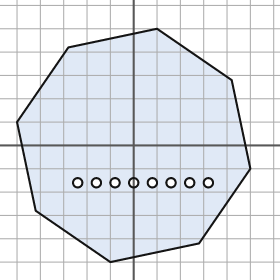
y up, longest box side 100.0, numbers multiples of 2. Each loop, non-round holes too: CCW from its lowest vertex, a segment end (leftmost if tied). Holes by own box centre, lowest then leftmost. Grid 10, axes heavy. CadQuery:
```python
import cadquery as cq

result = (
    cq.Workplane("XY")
    .moveTo(-10.0, -50.0)
    .lineTo(28.0, -42.0)
    .lineTo(50.0, -10.0)
    .lineTo(42.0, 28.0)
    .lineTo(10.0, 50.0)
    .lineTo(-28.0, 42.0)
    .lineTo(-50.0, 10.0)
    .lineTo(-42.0, -28.0)
    .close()
    .moveTo(-24.0, -16.0)
    .circle(2.0)
    .moveTo(-16.0, -16.0)
    .circle(2.0)
    .moveTo(-8.0, -16.0)
    .circle(2.0)
    .moveTo(0.0, -16.0)
    .circle(2.0)
    .moveTo(8.0, -16.0)
    .circle(2.0)
    .moveTo(16.0, -16.0)
    .circle(2.0)
    .moveTo(24.0, -16.0)
    .circle(2.0)
    .moveTo(32.0, -16.0)
    .circle(2.0)
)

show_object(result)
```